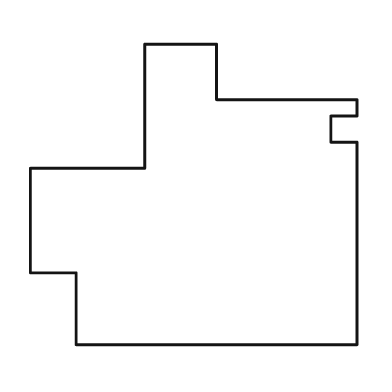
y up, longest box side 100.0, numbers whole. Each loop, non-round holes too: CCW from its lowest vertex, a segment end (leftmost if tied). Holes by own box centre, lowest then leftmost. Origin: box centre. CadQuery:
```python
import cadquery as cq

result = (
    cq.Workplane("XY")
    .moveTo(-36.0, -46.0)
    .lineTo(50.0, -46.0)
    .lineTo(50.0, 16.0)
    .lineTo(42.0, 16.0)
    .lineTo(42.0, 24.0)
    .lineTo(50.0, 24.0)
    .lineTo(50.0, 29.0)
    .lineTo(7.0, 29.0)
    .lineTo(7.0, 46.0)
    .lineTo(-15.0, 46.0)
    .lineTo(-15.0, 8.0)
    .lineTo(-50.0, 8.0)
    .lineTo(-50.0, -24.0)
    .lineTo(-36.0, -24.0)
    .close()
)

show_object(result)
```